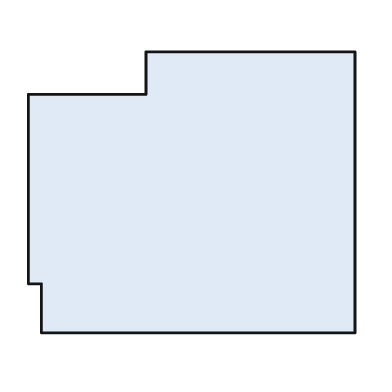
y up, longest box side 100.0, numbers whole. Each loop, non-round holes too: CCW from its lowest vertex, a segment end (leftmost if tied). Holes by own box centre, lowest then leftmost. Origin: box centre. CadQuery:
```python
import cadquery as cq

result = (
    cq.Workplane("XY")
    .moveTo(-46.0, -43.0)
    .lineTo(50.0, -43.0)
    .lineTo(50.0, 43.0)
    .lineTo(-14.0, 43.0)
    .lineTo(-14.0, 30.0)
    .lineTo(-50.0, 30.0)
    .lineTo(-50.0, -28.0)
    .lineTo(-46.0, -28.0)
    .close()
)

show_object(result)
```